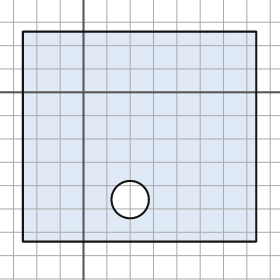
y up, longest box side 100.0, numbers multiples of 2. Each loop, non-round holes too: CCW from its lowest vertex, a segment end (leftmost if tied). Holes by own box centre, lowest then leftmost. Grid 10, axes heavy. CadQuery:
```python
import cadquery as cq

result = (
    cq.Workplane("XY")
    .moveTo(-26.0, -64.0)
    .lineTo(74.0, -64.0)
    .lineTo(74.0, 26.0)
    .lineTo(-26.0, 26.0)
    .close()
    .moveTo(20.0, -46.0)
    .circle(8.0)
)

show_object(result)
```